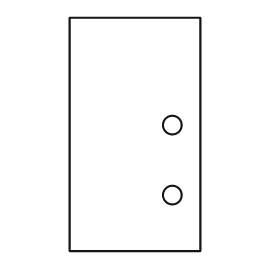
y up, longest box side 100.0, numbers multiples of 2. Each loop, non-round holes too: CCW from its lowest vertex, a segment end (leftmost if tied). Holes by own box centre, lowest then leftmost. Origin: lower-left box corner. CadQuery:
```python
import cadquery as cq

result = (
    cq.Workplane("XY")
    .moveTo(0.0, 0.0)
    .lineTo(56.0, 0.0)
    .lineTo(56.0, 100.0)
    .lineTo(0.0, 100.0)
    .close()
    .moveTo(44.0, 24.0)
    .circle(4.0)
    .moveTo(44.0, 54.0)
    .circle(4.0)
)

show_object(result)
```